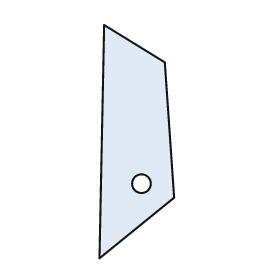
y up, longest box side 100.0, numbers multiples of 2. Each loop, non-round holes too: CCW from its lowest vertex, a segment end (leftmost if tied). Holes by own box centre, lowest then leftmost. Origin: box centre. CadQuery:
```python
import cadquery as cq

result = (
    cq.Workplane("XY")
    .moveTo(-16.0, -50.0)
    .lineTo(16.0, -24.0)
    .lineTo(12.0, 34.0)
    .lineTo(-14.0, 50.0)
    .close()
    .moveTo(2.0, -18.0)
    .circle(4.0)
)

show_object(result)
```